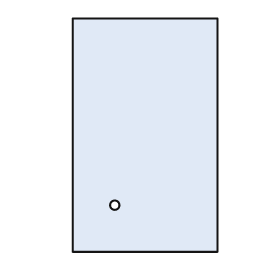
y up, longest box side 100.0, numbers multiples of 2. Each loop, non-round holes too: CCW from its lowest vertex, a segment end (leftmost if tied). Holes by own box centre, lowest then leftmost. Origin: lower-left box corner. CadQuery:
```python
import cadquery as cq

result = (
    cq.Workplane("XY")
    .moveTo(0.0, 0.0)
    .lineTo(62.0, 0.0)
    .lineTo(62.0, 100.0)
    .lineTo(0.0, 100.0)
    .close()
    .moveTo(18.0, 20.0)
    .circle(2.0)
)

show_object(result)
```